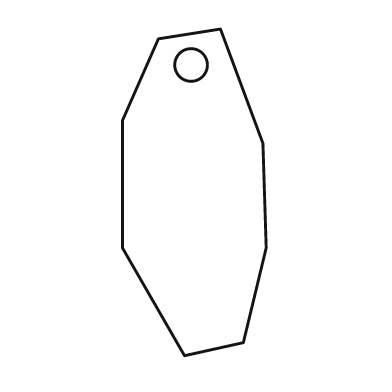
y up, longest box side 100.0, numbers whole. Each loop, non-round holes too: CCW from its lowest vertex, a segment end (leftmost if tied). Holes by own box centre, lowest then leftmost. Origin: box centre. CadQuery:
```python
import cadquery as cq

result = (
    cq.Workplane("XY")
    .moveTo(-3.0, -50.0)
    .lineTo(15.0, -46.0)
    .lineTo(22.0, -17.0)
    .lineTo(21.0, 15.0)
    .lineTo(8.0, 50.0)
    .lineTo(-11.0, 47.0)
    .lineTo(-22.0, 22.0)
    .lineTo(-22.0, -17.0)
    .close()
    .moveTo(-1.0, 39.0)
    .circle(5.0)
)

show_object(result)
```